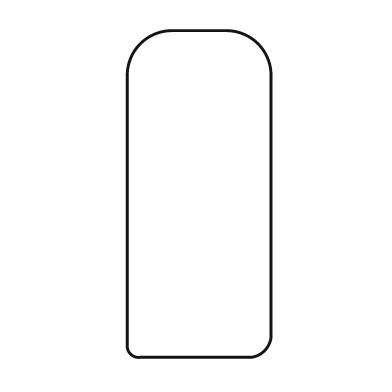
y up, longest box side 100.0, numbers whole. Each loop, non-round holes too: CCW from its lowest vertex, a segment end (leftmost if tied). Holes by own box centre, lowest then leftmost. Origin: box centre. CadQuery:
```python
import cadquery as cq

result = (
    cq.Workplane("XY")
    .moveTo(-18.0, -50.0)
    .lineTo(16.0, -50.0)
    .threePointArc((20.0, -48.0), (22.0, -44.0))
    .lineTo(22.0, 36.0)
    .threePointArc((18.0, 46.0), (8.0, 50.0))
    .lineTo(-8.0, 50.0)
    .threePointArc((-18.0, 46.0), (-22.0, 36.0))
    .lineTo(-22.0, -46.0)
    .threePointArc((-21.0, -49.0), (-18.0, -50.0))
    .close()
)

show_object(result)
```